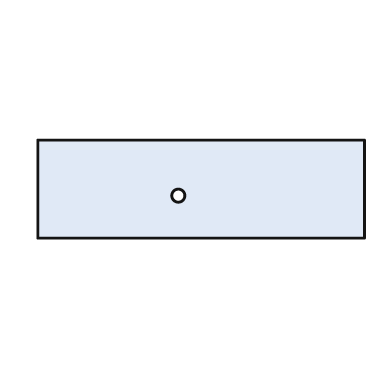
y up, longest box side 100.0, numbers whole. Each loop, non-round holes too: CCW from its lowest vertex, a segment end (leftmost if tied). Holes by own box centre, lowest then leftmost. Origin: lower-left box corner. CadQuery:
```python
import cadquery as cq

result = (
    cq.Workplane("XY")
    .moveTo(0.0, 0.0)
    .lineTo(100.0, 0.0)
    .lineTo(100.0, 30.0)
    .lineTo(0.0, 30.0)
    .close()
    .moveTo(43.0, 13.0)
    .circle(2.0)
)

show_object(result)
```